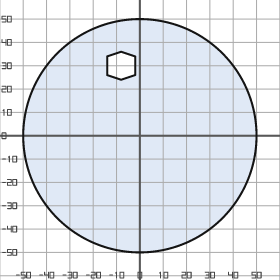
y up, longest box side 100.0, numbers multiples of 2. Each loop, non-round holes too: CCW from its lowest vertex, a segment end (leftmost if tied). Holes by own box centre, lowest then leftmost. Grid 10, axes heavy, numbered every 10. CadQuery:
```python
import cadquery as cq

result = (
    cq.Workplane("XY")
    .moveTo(0.0, 0.0)
    .circle(50.0)
    .moveTo(-8.0, 24.0)
    .lineTo(-2.0, 26.0)
    .lineTo(-2.0, 34.0)
    .lineTo(-8.0, 36.0)
    .lineTo(-14.0, 34.0)
    .lineTo(-14.0, 26.0)
    .close()
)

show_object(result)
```